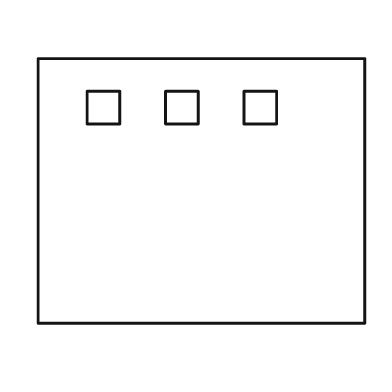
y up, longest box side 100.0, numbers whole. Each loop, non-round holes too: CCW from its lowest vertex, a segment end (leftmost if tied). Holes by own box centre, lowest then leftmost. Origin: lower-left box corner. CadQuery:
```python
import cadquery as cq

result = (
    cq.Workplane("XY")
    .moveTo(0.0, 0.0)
    .lineTo(100.0, 0.0)
    .lineTo(100.0, 81.0)
    .lineTo(0.0, 81.0)
    .close()
    .moveTo(15.0, 61.0)
    .lineTo(25.0, 61.0)
    .lineTo(25.0, 71.0)
    .lineTo(15.0, 71.0)
    .close()
    .moveTo(39.0, 61.0)
    .lineTo(49.0, 61.0)
    .lineTo(49.0, 71.0)
    .lineTo(39.0, 71.0)
    .close()
    .moveTo(63.0, 61.0)
    .lineTo(73.0, 61.0)
    .lineTo(73.0, 71.0)
    .lineTo(63.0, 71.0)
    .close()
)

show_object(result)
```